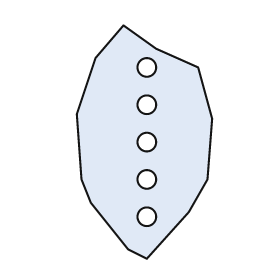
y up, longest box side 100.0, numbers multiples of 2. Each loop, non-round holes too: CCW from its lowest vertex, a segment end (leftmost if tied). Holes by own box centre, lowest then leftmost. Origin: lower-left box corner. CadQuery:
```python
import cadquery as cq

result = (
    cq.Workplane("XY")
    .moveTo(30.0, 0.0)
    .lineTo(48.0, 20.0)
    .lineTo(56.0, 34.0)
    .lineTo(58.0, 60.0)
    .lineTo(52.0, 82.0)
    .lineTo(34.0, 90.0)
    .lineTo(20.0, 100.0)
    .lineTo(8.0, 86.0)
    .lineTo(0.0, 62.0)
    .lineTo(2.0, 34.0)
    .lineTo(6.0, 24.0)
    .lineTo(22.0, 4.0)
    .close()
    .moveTo(30.0, 18.0)
    .circle(4.0)
    .moveTo(30.0, 34.0)
    .circle(4.0)
    .moveTo(30.0, 50.0)
    .circle(4.0)
    .moveTo(30.0, 66.0)
    .circle(4.0)
    .moveTo(30.0, 82.0)
    .circle(4.0)
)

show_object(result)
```